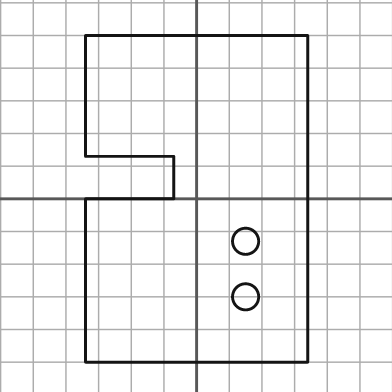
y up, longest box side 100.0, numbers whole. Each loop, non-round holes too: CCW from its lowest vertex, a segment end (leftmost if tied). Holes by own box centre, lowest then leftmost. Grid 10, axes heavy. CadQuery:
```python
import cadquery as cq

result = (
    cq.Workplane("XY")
    .moveTo(-34.0, -50.0)
    .lineTo(34.0, -50.0)
    .lineTo(34.0, 50.0)
    .lineTo(-34.0, 50.0)
    .lineTo(-34.0, 13.0)
    .lineTo(-7.0, 13.0)
    .lineTo(-7.0, 0.0)
    .lineTo(-34.0, 0.0)
    .close()
    .moveTo(15.0, -30.0)
    .circle(4.0)
    .moveTo(15.0, -13.0)
    .circle(4.0)
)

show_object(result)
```